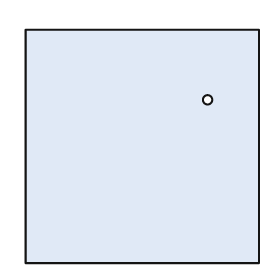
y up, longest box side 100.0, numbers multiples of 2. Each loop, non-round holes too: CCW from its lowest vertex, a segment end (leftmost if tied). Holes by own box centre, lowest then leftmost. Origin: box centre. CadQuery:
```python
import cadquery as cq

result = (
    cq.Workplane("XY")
    .moveTo(-50.0, -50.0)
    .lineTo(50.0, -50.0)
    .lineTo(50.0, 50.0)
    .lineTo(-50.0, 50.0)
    .close()
    .moveTo(28.0, 20.0)
    .circle(2.0)
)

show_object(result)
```